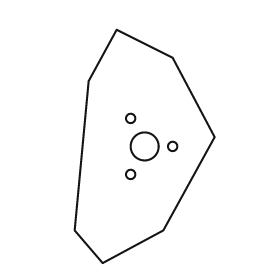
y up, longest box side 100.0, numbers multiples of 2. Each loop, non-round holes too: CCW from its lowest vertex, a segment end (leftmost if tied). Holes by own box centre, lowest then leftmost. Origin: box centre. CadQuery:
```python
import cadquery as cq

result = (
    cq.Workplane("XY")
    .moveTo(-18.0, -50.0)
    .lineTo(8.0, -36.0)
    .lineTo(30.0, 4.0)
    .lineTo(12.0, 38.0)
    .lineTo(-12.0, 50.0)
    .lineTo(-24.0, 28.0)
    .lineTo(-30.0, -36.0)
    .close()
    .moveTo(-6.0, -12.0)
    .circle(2.0)
    .moveTo(0.0, 0.0)
    .circle(6.0)
    .moveTo(12.0, 0.0)
    .circle(2.0)
    .moveTo(-6.0, 12.0)
    .circle(2.0)
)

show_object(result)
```